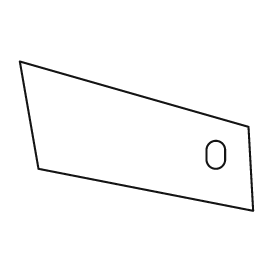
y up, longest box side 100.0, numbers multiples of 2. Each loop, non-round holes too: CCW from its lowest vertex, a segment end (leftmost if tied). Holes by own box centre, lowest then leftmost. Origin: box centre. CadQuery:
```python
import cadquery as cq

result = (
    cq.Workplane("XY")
    .moveTo(50.0, -32.0)
    .lineTo(48.0, 4.0)
    .lineTo(-50.0, 32.0)
    .lineTo(-42.0, -14.0)
    .close()
    .moveTo(30.0, -10.0)
    .threePointArc((34.0, -14.0), (38.0, -10.0))
    .lineTo(38.0, -6.0)
    .threePointArc((34.0, -2.0), (30.0, -6.0))
    .close()
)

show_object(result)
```